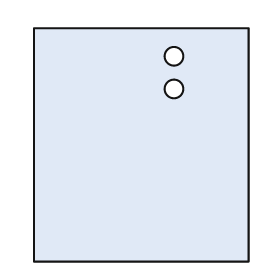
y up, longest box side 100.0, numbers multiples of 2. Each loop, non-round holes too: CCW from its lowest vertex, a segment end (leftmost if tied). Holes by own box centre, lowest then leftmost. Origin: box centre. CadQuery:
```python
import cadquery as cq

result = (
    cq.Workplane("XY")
    .moveTo(-46.0, -50.0)
    .lineTo(46.0, -50.0)
    .lineTo(46.0, 50.0)
    .lineTo(-46.0, 50.0)
    .close()
    .moveTo(14.0, 24.0)
    .circle(4.0)
    .moveTo(14.0, 38.0)
    .circle(4.0)
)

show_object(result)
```